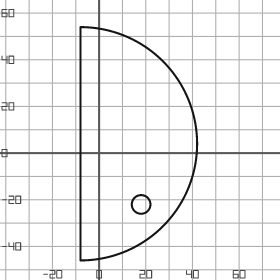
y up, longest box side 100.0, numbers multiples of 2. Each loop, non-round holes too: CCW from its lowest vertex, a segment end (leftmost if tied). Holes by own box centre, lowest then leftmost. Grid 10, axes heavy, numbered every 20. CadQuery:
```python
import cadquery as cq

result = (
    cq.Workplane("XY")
    .moveTo(-8.0, -46.0)
    .threePointArc((42.0, 4.0), (-8.0, 54.0))
    .close()
    .moveTo(18.0, -22.0)
    .circle(4.0)
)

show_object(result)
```